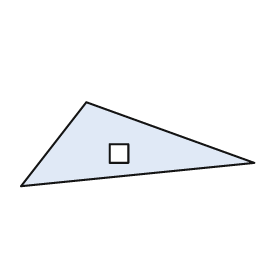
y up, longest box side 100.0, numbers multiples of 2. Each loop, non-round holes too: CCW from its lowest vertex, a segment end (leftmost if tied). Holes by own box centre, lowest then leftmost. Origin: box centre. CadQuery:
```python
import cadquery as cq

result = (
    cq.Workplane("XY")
    .moveTo(-50.0, -18.0)
    .lineTo(50.0, -8.0)
    .lineTo(-22.0, 18.0)
    .close()
    .moveTo(-12.0, -8.0)
    .lineTo(-4.0, -8.0)
    .lineTo(-4.0, 0.0)
    .lineTo(-12.0, 0.0)
    .close()
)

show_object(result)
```